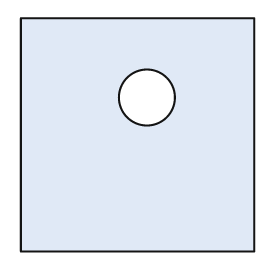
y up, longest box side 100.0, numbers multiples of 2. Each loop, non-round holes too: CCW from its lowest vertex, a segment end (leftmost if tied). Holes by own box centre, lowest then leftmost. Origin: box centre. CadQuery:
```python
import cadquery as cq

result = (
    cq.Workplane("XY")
    .moveTo(-50.0, -50.0)
    .lineTo(50.0, -50.0)
    .lineTo(50.0, 50.0)
    .lineTo(-50.0, 50.0)
    .close()
    .moveTo(4.0, 16.0)
    .circle(12.0)
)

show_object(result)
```